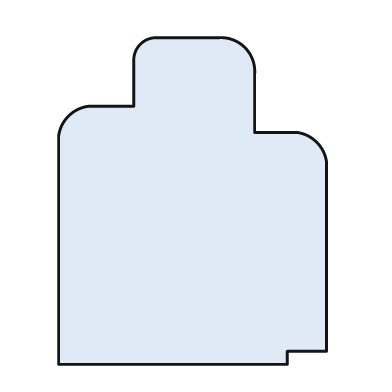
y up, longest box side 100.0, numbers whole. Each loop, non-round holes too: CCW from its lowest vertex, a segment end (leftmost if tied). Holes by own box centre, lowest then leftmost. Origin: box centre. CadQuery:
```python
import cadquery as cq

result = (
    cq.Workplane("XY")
    .moveTo(-41.0, -50.0)
    .lineTo(29.0, -50.0)
    .lineTo(29.0, -46.0)
    .lineTo(41.0, -46.0)
    .lineTo(41.0, 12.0)
    .threePointArc((38.0, 18.0), (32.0, 21.0))
    .lineTo(19.0, 21.0)
    .lineTo(19.0, 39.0)
    .threePointArc((16.0, 47.0), (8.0, 50.0))
    .lineTo(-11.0, 50.0)
    .threePointArc((-16.0, 48.0), (-18.0, 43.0))
    .lineTo(-18.0, 29.0)
    .lineTo(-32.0, 29.0)
    .threePointArc((-38.0, 26.0), (-41.0, 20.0))
    .close()
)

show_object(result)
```